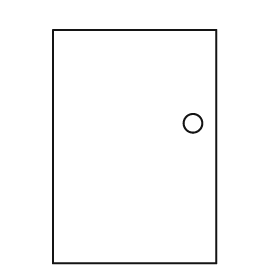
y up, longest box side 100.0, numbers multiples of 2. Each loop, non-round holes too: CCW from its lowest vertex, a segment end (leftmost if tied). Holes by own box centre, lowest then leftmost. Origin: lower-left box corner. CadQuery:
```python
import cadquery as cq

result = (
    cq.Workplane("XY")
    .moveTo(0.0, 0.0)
    .lineTo(70.0, 0.0)
    .lineTo(70.0, 100.0)
    .lineTo(0.0, 100.0)
    .close()
    .moveTo(60.0, 60.0)
    .circle(4.0)
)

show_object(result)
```